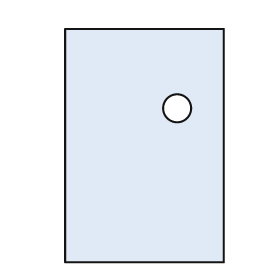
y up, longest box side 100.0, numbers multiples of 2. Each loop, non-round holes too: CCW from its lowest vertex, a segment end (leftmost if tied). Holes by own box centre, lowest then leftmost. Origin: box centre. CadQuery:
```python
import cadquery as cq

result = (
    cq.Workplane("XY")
    .moveTo(-34.0, -50.0)
    .lineTo(34.0, -50.0)
    .lineTo(34.0, 50.0)
    .lineTo(-34.0, 50.0)
    .close()
    .moveTo(14.0, 16.0)
    .circle(6.0)
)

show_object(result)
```